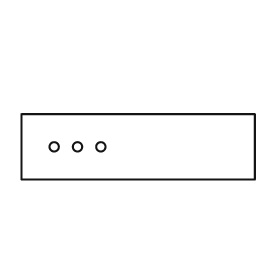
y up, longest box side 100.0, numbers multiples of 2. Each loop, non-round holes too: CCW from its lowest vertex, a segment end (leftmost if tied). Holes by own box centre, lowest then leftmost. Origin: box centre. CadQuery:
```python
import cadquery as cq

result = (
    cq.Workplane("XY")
    .moveTo(-50.0, -14.0)
    .lineTo(50.0, -14.0)
    .lineTo(50.0, 14.0)
    .lineTo(-50.0, 14.0)
    .close()
    .moveTo(-36.0, 0.0)
    .circle(2.0)
    .moveTo(-26.0, 0.0)
    .circle(2.0)
    .moveTo(-16.0, 0.0)
    .circle(2.0)
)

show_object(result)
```